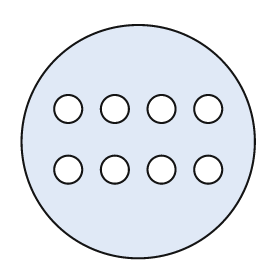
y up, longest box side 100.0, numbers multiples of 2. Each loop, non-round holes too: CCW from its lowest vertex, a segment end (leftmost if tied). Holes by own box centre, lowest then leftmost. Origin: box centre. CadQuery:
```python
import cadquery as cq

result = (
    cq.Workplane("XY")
    .moveTo(0.0, 0.0)
    .circle(50.0)
    .moveTo(-30.0, -12.0)
    .circle(6.0)
    .moveTo(-10.0, -12.0)
    .circle(6.0)
    .moveTo(10.0, -12.0)
    .circle(6.0)
    .moveTo(30.0, -12.0)
    .circle(6.0)
    .moveTo(-30.0, 14.0)
    .circle(6.0)
    .moveTo(-10.0, 14.0)
    .circle(6.0)
    .moveTo(10.0, 14.0)
    .circle(6.0)
    .moveTo(30.0, 14.0)
    .circle(6.0)
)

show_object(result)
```